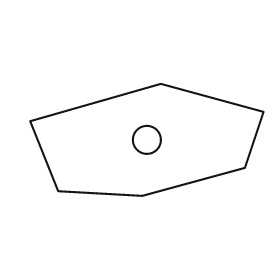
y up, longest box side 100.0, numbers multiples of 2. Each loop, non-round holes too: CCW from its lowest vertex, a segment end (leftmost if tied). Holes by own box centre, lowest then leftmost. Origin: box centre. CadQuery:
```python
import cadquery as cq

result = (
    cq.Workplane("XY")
    .moveTo(-2.0, -24.0)
    .lineTo(42.0, -12.0)
    .lineTo(50.0, 12.0)
    .lineTo(6.0, 24.0)
    .lineTo(-50.0, 8.0)
    .lineTo(-38.0, -22.0)
    .close()
    .moveTo(0.0, 0.0)
    .circle(6.0)
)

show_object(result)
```